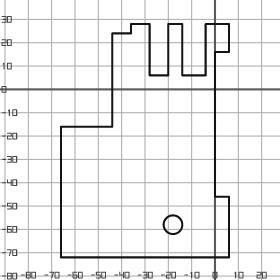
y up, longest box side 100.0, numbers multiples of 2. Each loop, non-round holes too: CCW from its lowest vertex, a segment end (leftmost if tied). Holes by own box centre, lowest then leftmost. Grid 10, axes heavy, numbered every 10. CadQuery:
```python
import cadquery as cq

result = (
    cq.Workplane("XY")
    .moveTo(-66.0, -72.0)
    .lineTo(6.0, -72.0)
    .lineTo(6.0, -46.0)
    .lineTo(0.0, -46.0)
    .lineTo(0.0, 16.0)
    .lineTo(6.0, 16.0)
    .lineTo(6.0, 28.0)
    .lineTo(-4.0, 28.0)
    .lineTo(-4.0, 6.0)
    .lineTo(-14.0, 6.0)
    .lineTo(-14.0, 28.0)
    .lineTo(-20.0, 28.0)
    .lineTo(-20.0, 6.0)
    .lineTo(-28.0, 6.0)
    .lineTo(-28.0, 28.0)
    .lineTo(-36.0, 28.0)
    .lineTo(-36.0, 24.0)
    .lineTo(-44.0, 24.0)
    .lineTo(-44.0, -16.0)
    .lineTo(-66.0, -16.0)
    .close()
    .moveTo(-18.0, -58.0)
    .circle(4.0)
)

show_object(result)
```